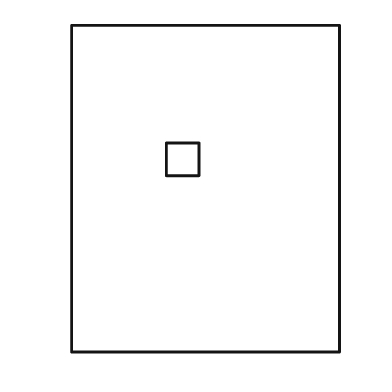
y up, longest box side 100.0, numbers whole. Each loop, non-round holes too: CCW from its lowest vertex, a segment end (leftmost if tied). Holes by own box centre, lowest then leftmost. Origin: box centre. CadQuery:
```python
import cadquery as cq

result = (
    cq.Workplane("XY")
    .moveTo(-41.0, -50.0)
    .lineTo(41.0, -50.0)
    .lineTo(41.0, 50.0)
    .lineTo(-41.0, 50.0)
    .close()
    .moveTo(-12.0, 4.0)
    .lineTo(-2.0, 4.0)
    .lineTo(-2.0, 14.0)
    .lineTo(-12.0, 14.0)
    .close()
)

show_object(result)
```